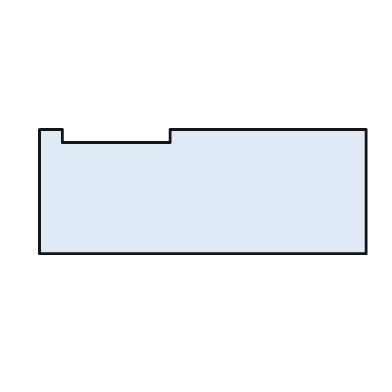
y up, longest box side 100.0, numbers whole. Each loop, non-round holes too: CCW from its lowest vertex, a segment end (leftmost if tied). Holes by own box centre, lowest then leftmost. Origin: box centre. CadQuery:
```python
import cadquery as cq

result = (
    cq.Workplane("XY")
    .moveTo(-50.0, -19.0)
    .lineTo(50.0, -19.0)
    .lineTo(50.0, 19.0)
    .lineTo(-10.0, 19.0)
    .lineTo(-10.0, 15.0)
    .lineTo(-43.0, 15.0)
    .lineTo(-43.0, 19.0)
    .lineTo(-50.0, 19.0)
    .close()
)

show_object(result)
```